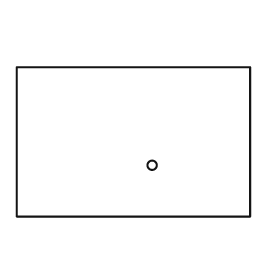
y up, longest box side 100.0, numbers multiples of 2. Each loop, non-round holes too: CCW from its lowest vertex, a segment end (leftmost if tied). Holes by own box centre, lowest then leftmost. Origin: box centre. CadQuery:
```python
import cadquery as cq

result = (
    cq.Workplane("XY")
    .moveTo(-50.0, -32.0)
    .lineTo(50.0, -32.0)
    .lineTo(50.0, 32.0)
    .lineTo(-50.0, 32.0)
    .close()
    .moveTo(8.0, -10.0)
    .circle(2.0)
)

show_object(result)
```